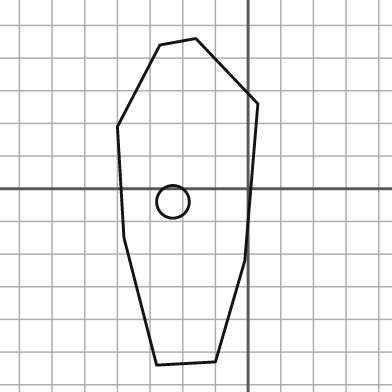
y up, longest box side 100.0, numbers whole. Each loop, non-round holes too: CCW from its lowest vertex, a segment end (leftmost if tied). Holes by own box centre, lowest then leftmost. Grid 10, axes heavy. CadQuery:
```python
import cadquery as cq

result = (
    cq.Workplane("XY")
    .moveTo(-28.0, -54.0)
    .lineTo(-10.0, -53.0)
    .lineTo(-1.0, -22.0)
    .lineTo(3.0, 26.0)
    .lineTo(-16.0, 46.0)
    .lineTo(-27.0, 44.0)
    .lineTo(-40.0, 19.0)
    .lineTo(-38.0, -15.0)
    .close()
    .moveTo(-23.0, -4.0)
    .circle(5.0)
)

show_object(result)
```